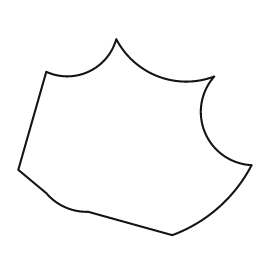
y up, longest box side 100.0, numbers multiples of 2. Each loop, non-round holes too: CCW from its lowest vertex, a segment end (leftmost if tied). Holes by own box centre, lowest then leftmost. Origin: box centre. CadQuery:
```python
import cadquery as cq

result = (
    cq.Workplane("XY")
    .moveTo(16.0, -42.0)
    .threePointArc((36.0, -30.0), (50.0, -12.0))
    .threePointArc((30.0, 2.0), (34.0, 26.0))
    .threePointArc((10.0, 26.0), (-8.0, 42.0))
    .threePointArc((-20.0, 28.0), (-38.0, 28.0))
    .lineTo(-50.0, -14.0)
    .lineTo(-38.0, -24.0)
    .threePointArc((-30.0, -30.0), (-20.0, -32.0))
    .close()
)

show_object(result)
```